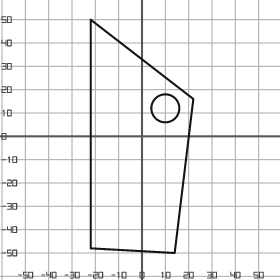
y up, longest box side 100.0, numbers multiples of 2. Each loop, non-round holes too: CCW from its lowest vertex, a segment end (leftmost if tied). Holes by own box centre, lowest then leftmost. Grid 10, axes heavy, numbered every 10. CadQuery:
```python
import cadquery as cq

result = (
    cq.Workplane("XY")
    .moveTo(14.0, -50.0)
    .lineTo(22.0, 16.0)
    .lineTo(-22.0, 50.0)
    .lineTo(-22.0, -48.0)
    .close()
    .moveTo(10.0, 12.0)
    .circle(6.0)
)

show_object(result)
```